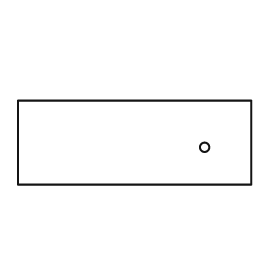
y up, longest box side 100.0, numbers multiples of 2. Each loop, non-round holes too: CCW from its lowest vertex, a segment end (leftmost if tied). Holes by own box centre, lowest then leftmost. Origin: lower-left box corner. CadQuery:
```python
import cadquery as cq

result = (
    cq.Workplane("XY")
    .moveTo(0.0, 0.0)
    .lineTo(100.0, 0.0)
    .lineTo(100.0, 36.0)
    .lineTo(0.0, 36.0)
    .close()
    .moveTo(80.0, 16.0)
    .circle(2.0)
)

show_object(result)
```